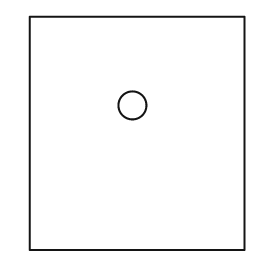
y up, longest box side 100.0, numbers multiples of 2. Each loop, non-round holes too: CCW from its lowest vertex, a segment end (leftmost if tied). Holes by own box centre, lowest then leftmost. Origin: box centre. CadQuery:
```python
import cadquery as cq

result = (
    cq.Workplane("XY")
    .moveTo(-46.0, -50.0)
    .lineTo(46.0, -50.0)
    .lineTo(46.0, 50.0)
    .lineTo(-46.0, 50.0)
    .close()
    .moveTo(-2.0, 12.0)
    .circle(6.0)
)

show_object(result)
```